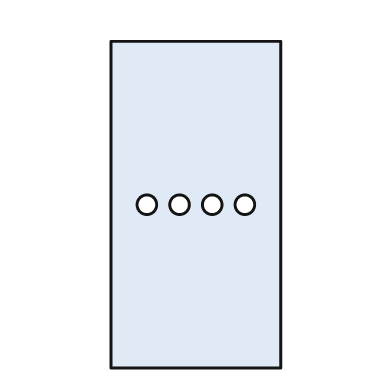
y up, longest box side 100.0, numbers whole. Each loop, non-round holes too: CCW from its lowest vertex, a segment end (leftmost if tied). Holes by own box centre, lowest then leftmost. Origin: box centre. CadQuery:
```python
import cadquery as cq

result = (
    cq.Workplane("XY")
    .moveTo(-26.0, -50.0)
    .lineTo(26.0, -50.0)
    .lineTo(26.0, 50.0)
    .lineTo(-26.0, 50.0)
    .close()
    .moveTo(-15.0, 0.0)
    .circle(3.0)
    .moveTo(-5.0, 0.0)
    .circle(3.0)
    .moveTo(5.0, 0.0)
    .circle(3.0)
    .moveTo(15.0, 0.0)
    .circle(3.0)
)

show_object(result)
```